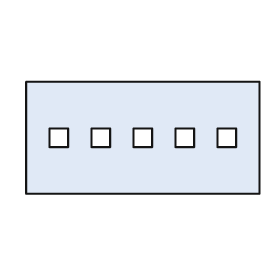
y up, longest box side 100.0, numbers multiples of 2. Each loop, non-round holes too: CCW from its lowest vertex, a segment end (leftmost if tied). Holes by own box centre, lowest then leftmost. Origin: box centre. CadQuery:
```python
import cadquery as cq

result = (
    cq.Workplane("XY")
    .moveTo(-50.0, -24.0)
    .lineTo(50.0, -24.0)
    .lineTo(50.0, 24.0)
    .lineTo(-50.0, 24.0)
    .close()
    .moveTo(-40.0, -4.0)
    .lineTo(-32.0, -4.0)
    .lineTo(-32.0, 4.0)
    .lineTo(-40.0, 4.0)
    .close()
    .moveTo(-22.0, -4.0)
    .lineTo(-14.0, -4.0)
    .lineTo(-14.0, 4.0)
    .lineTo(-22.0, 4.0)
    .close()
    .moveTo(-4.0, -4.0)
    .lineTo(4.0, -4.0)
    .lineTo(4.0, 4.0)
    .lineTo(-4.0, 4.0)
    .close()
    .moveTo(14.0, -4.0)
    .lineTo(22.0, -4.0)
    .lineTo(22.0, 4.0)
    .lineTo(14.0, 4.0)
    .close()
    .moveTo(32.0, -4.0)
    .lineTo(40.0, -4.0)
    .lineTo(40.0, 4.0)
    .lineTo(32.0, 4.0)
    .close()
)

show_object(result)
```